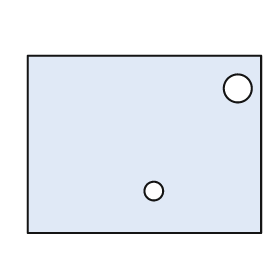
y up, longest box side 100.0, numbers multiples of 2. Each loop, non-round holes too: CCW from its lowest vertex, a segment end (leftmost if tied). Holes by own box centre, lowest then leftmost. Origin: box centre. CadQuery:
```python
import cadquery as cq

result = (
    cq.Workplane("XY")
    .moveTo(-50.0, -38.0)
    .lineTo(50.0, -38.0)
    .lineTo(50.0, 38.0)
    .lineTo(-50.0, 38.0)
    .close()
    .moveTo(4.0, -20.0)
    .circle(4.0)
    .moveTo(40.0, 24.0)
    .circle(6.0)
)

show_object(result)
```